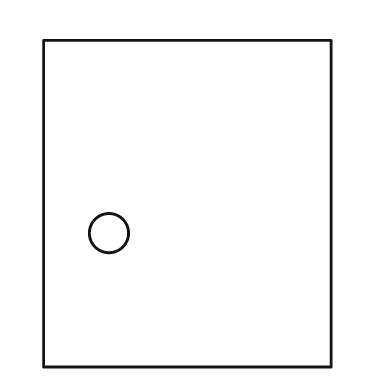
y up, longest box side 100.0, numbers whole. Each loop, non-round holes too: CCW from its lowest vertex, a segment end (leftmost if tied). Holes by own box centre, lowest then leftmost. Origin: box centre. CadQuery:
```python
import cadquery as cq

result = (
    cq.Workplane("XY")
    .moveTo(-44.0, -50.0)
    .lineTo(44.0, -50.0)
    .lineTo(44.0, 50.0)
    .lineTo(-44.0, 50.0)
    .close()
    .moveTo(-24.0, -9.0)
    .circle(6.0)
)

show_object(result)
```